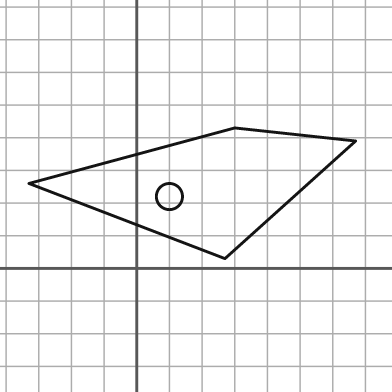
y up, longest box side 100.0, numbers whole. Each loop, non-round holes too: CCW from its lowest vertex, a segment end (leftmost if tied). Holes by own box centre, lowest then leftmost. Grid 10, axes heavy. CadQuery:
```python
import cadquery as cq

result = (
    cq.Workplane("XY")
    .moveTo(27.0, 3.0)
    .lineTo(67.0, 39.0)
    .lineTo(30.0, 43.0)
    .lineTo(-33.0, 26.0)
    .close()
    .moveTo(10.0, 22.0)
    .circle(4.0)
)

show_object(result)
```